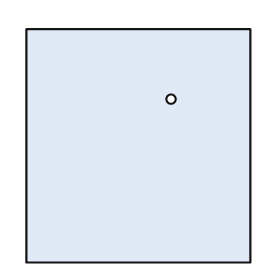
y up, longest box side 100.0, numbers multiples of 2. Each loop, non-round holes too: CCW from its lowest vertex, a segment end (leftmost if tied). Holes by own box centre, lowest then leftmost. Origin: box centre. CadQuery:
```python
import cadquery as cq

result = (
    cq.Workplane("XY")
    .moveTo(-48.0, -50.0)
    .lineTo(48.0, -50.0)
    .lineTo(48.0, 50.0)
    .lineTo(-48.0, 50.0)
    .close()
    .moveTo(14.0, 20.0)
    .circle(2.0)
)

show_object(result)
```